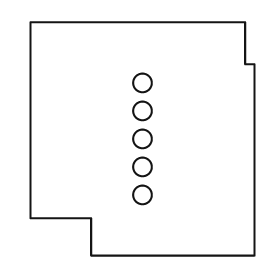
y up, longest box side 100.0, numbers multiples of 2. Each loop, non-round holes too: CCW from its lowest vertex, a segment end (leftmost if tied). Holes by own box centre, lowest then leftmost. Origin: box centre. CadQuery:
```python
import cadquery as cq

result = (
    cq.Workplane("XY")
    .moveTo(-22.0, -50.0)
    .lineTo(48.0, -50.0)
    .lineTo(48.0, 32.0)
    .lineTo(44.0, 32.0)
    .lineTo(44.0, 50.0)
    .lineTo(-48.0, 50.0)
    .lineTo(-48.0, -34.0)
    .lineTo(-22.0, -34.0)
    .close()
    .moveTo(0.0, -24.0)
    .circle(4.0)
    .moveTo(0.0, -12.0)
    .circle(4.0)
    .moveTo(0.0, 0.0)
    .circle(4.0)
    .moveTo(0.0, 12.0)
    .circle(4.0)
    .moveTo(0.0, 24.0)
    .circle(4.0)
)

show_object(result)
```